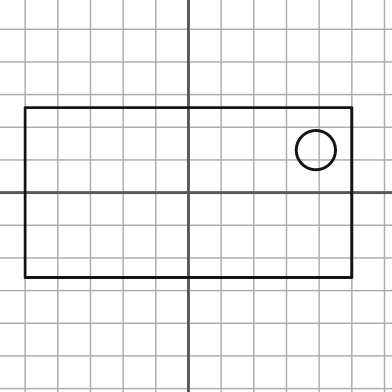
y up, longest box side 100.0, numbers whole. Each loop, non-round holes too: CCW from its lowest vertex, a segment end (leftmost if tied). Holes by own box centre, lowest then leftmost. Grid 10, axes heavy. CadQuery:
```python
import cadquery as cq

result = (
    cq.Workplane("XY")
    .moveTo(-50.0, -26.0)
    .lineTo(50.0, -26.0)
    .lineTo(50.0, 26.0)
    .lineTo(-50.0, 26.0)
    .close()
    .moveTo(39.0, 13.0)
    .circle(6.0)
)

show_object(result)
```